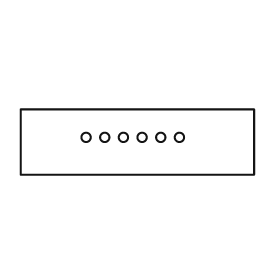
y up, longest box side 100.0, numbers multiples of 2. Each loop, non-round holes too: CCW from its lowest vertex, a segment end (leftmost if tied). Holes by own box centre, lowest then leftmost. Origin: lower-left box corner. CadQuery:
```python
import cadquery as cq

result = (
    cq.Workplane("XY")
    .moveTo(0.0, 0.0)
    .lineTo(100.0, 0.0)
    .lineTo(100.0, 28.0)
    .lineTo(0.0, 28.0)
    .close()
    .moveTo(28.0, 16.0)
    .circle(2.0)
    .moveTo(36.0, 16.0)
    .circle(2.0)
    .moveTo(44.0, 16.0)
    .circle(2.0)
    .moveTo(52.0, 16.0)
    .circle(2.0)
    .moveTo(60.0, 16.0)
    .circle(2.0)
    .moveTo(68.0, 16.0)
    .circle(2.0)
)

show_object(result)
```